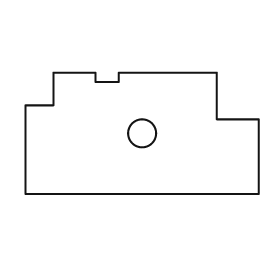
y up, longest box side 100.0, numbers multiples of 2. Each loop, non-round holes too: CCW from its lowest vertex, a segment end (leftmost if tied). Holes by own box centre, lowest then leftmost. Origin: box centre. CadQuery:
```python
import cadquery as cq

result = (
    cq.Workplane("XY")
    .moveTo(-50.0, -26.0)
    .lineTo(50.0, -26.0)
    .lineTo(50.0, 6.0)
    .lineTo(32.0, 6.0)
    .lineTo(32.0, 26.0)
    .lineTo(-10.0, 26.0)
    .lineTo(-10.0, 22.0)
    .lineTo(-20.0, 22.0)
    .lineTo(-20.0, 26.0)
    .lineTo(-38.0, 26.0)
    .lineTo(-38.0, 12.0)
    .lineTo(-50.0, 12.0)
    .close()
    .moveTo(0.0, 0.0)
    .circle(6.0)
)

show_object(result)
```